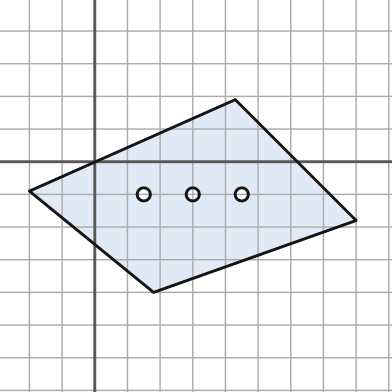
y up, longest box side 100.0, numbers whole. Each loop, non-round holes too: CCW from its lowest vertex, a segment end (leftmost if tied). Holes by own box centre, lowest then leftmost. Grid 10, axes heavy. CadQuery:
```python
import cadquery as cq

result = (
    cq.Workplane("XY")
    .moveTo(18.0, -40.0)
    .lineTo(80.0, -18.0)
    .lineTo(43.0, 19.0)
    .lineTo(-20.0, -9.0)
    .close()
    .moveTo(15.0, -10.0)
    .circle(2.0)
    .moveTo(30.0, -10.0)
    .circle(2.0)
    .moveTo(45.0, -10.0)
    .circle(2.0)
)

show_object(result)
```